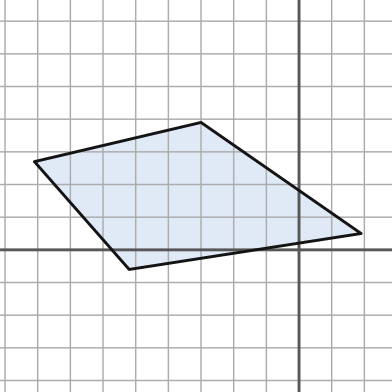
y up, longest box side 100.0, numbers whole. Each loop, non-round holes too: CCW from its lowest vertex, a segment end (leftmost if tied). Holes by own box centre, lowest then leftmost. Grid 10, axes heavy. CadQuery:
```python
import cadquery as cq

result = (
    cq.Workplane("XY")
    .moveTo(-52.0, -6.0)
    .lineTo(19.0, 5.0)
    .lineTo(-30.0, 39.0)
    .lineTo(-81.0, 27.0)
    .close()
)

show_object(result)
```